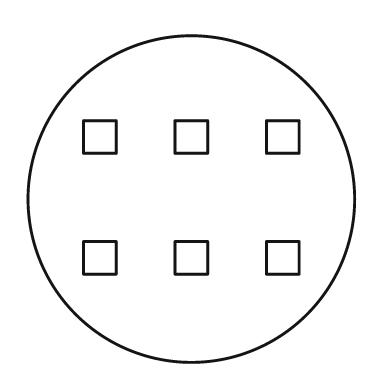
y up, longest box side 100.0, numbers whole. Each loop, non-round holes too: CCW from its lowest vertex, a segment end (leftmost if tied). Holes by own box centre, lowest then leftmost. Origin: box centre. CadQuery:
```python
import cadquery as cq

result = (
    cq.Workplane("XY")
    .moveTo(0.0, 0.0)
    .circle(50.0)
    .moveTo(-33.0, -23.0)
    .lineTo(-23.0, -23.0)
    .lineTo(-23.0, -13.0)
    .lineTo(-33.0, -13.0)
    .close()
    .moveTo(-5.0, -23.0)
    .lineTo(5.0, -23.0)
    .lineTo(5.0, -13.0)
    .lineTo(-5.0, -13.0)
    .close()
    .moveTo(23.0, -23.0)
    .lineTo(33.0, -23.0)
    .lineTo(33.0, -13.0)
    .lineTo(23.0, -13.0)
    .close()
    .moveTo(-33.0, 14.0)
    .lineTo(-23.0, 14.0)
    .lineTo(-23.0, 24.0)
    .lineTo(-33.0, 24.0)
    .close()
    .moveTo(-5.0, 14.0)
    .lineTo(5.0, 14.0)
    .lineTo(5.0, 24.0)
    .lineTo(-5.0, 24.0)
    .close()
    .moveTo(23.0, 14.0)
    .lineTo(33.0, 14.0)
    .lineTo(33.0, 24.0)
    .lineTo(23.0, 24.0)
    .close()
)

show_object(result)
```